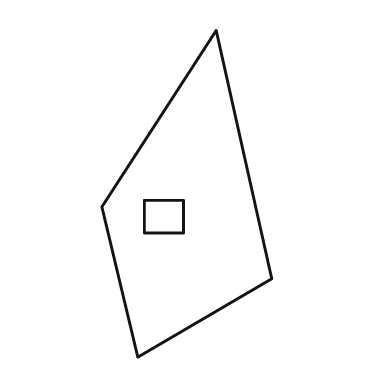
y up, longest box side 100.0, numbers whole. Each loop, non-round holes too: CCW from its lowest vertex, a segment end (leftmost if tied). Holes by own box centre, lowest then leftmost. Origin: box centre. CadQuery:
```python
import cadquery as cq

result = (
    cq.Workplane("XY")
    .moveTo(-15.0, -50.0)
    .lineTo(26.0, -26.0)
    .lineTo(9.0, 50.0)
    .lineTo(-26.0, -4.0)
    .close()
    .moveTo(-13.0, -12.0)
    .lineTo(-1.0, -12.0)
    .lineTo(-1.0, -2.0)
    .lineTo(-13.0, -2.0)
    .close()
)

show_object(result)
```